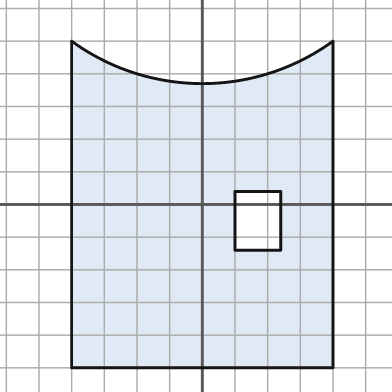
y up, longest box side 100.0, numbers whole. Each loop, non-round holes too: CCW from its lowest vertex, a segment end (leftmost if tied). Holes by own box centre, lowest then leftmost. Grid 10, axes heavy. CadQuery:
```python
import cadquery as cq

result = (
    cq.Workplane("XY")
    .moveTo(-40.0, -50.0)
    .lineTo(40.0, -50.0)
    .lineTo(40.0, 50.0)
    .threePointArc((0.0, 37.0), (-40.0, 50.0))
    .close()
    .moveTo(10.0, -14.0)
    .lineTo(24.0, -14.0)
    .lineTo(24.0, 4.0)
    .lineTo(10.0, 4.0)
    .close()
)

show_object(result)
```